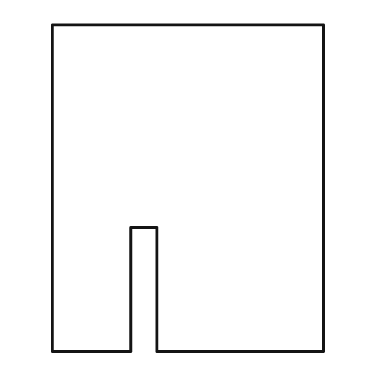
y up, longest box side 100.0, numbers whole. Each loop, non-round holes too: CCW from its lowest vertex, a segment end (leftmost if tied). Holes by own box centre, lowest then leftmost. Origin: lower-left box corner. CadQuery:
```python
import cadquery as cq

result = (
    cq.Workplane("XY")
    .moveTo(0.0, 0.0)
    .lineTo(24.0, 0.0)
    .lineTo(24.0, 38.0)
    .lineTo(32.0, 38.0)
    .lineTo(32.0, 0.0)
    .lineTo(83.0, 0.0)
    .lineTo(83.0, 100.0)
    .lineTo(0.0, 100.0)
    .close()
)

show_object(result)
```